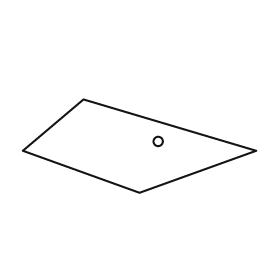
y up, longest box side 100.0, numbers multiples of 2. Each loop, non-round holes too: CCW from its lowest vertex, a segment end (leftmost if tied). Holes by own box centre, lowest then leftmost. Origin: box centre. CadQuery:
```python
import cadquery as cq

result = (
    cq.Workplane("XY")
    .moveTo(0.0, -20.0)
    .lineTo(50.0, -2.0)
    .lineTo(-24.0, 20.0)
    .lineTo(-50.0, -2.0)
    .close()
    .moveTo(8.0, 2.0)
    .circle(2.0)
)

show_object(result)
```